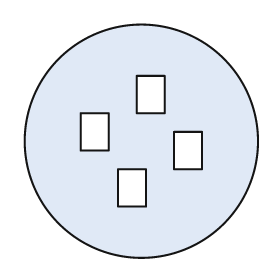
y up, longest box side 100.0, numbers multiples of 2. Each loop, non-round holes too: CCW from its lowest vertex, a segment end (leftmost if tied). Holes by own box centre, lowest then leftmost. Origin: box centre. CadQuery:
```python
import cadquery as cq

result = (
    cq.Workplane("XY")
    .moveTo(0.0, 0.0)
    .circle(50.0)
    .moveTo(-10.0, -28.0)
    .lineTo(2.0, -28.0)
    .lineTo(2.0, -12.0)
    .lineTo(-10.0, -12.0)
    .close()
    .moveTo(14.0, -12.0)
    .lineTo(26.0, -12.0)
    .lineTo(26.0, 4.0)
    .lineTo(14.0, 4.0)
    .close()
    .moveTo(-26.0, -4.0)
    .lineTo(-14.0, -4.0)
    .lineTo(-14.0, 12.0)
    .lineTo(-26.0, 12.0)
    .close()
    .moveTo(-2.0, 12.0)
    .lineTo(10.0, 12.0)
    .lineTo(10.0, 28.0)
    .lineTo(-2.0, 28.0)
    .close()
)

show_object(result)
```